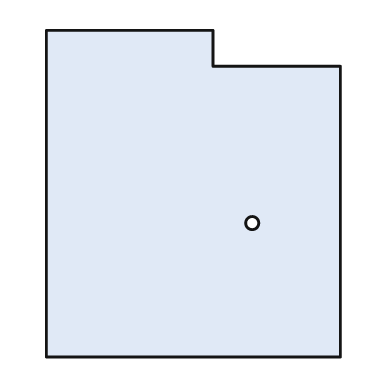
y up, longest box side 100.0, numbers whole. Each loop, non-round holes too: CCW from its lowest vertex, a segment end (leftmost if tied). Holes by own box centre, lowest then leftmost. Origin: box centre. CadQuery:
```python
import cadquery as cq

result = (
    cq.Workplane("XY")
    .moveTo(-45.0, -50.0)
    .lineTo(45.0, -50.0)
    .lineTo(45.0, 39.0)
    .lineTo(6.0, 39.0)
    .lineTo(6.0, 50.0)
    .lineTo(-45.0, 50.0)
    .close()
    .moveTo(18.0, -9.0)
    .circle(2.0)
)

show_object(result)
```